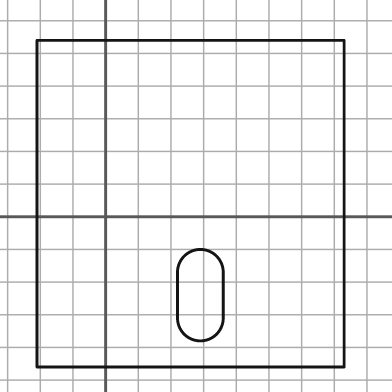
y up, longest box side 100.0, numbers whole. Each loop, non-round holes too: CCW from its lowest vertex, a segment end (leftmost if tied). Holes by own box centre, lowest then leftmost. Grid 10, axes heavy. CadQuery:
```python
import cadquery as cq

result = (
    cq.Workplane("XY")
    .moveTo(-21.0, -46.0)
    .lineTo(73.0, -46.0)
    .lineTo(73.0, 54.0)
    .lineTo(-21.0, 54.0)
    .close()
    .moveTo(22.0, -31.0)
    .threePointArc((29.0, -38.0), (36.0, -31.0))
    .lineTo(36.0, -17.0)
    .threePointArc((29.0, -10.0), (22.0, -17.0))
    .close()
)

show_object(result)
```